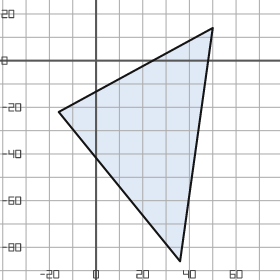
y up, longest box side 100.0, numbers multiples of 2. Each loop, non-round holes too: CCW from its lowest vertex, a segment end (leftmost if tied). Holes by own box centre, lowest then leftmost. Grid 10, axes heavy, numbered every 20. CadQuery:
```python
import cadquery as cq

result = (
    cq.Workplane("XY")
    .moveTo(36.0, -86.0)
    .lineTo(50.0, 14.0)
    .lineTo(-16.0, -22.0)
    .close()
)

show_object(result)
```